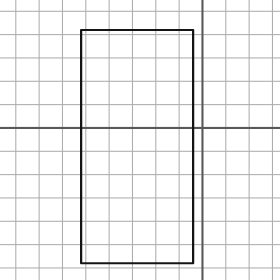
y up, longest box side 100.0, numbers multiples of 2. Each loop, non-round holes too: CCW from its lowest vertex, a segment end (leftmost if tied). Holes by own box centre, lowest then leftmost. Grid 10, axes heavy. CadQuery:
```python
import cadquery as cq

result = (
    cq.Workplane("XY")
    .moveTo(-52.0, -58.0)
    .lineTo(-4.0, -58.0)
    .lineTo(-4.0, 42.0)
    .lineTo(-52.0, 42.0)
    .close()
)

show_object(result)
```